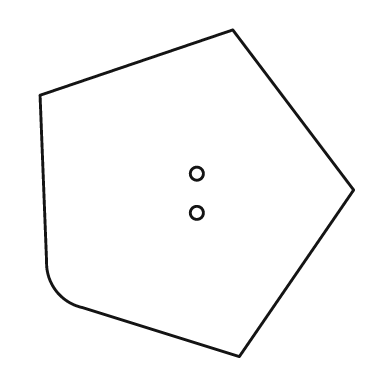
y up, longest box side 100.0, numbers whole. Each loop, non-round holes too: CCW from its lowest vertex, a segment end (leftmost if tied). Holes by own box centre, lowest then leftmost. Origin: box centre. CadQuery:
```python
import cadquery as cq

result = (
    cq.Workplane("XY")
    .moveTo(13.0, -50.0)
    .lineTo(48.0, 1.0)
    .lineTo(11.0, 50.0)
    .lineTo(-48.0, 30.0)
    .lineTo(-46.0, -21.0)
    .threePointArc((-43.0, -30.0), (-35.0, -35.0))
    .close()
    .moveTo(0.0, -6.0)
    .circle(2.0)
    .moveTo(0.0, 6.0)
    .circle(2.0)
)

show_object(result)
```